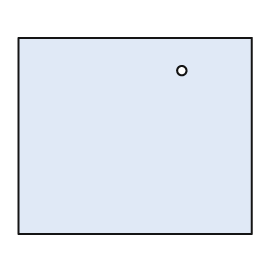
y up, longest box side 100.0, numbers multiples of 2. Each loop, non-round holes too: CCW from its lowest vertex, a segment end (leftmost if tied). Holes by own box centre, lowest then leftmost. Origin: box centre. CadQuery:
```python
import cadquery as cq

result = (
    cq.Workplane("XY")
    .moveTo(-50.0, -42.0)
    .lineTo(50.0, -42.0)
    .lineTo(50.0, 42.0)
    .lineTo(-50.0, 42.0)
    .close()
    .moveTo(20.0, 28.0)
    .circle(2.0)
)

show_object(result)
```